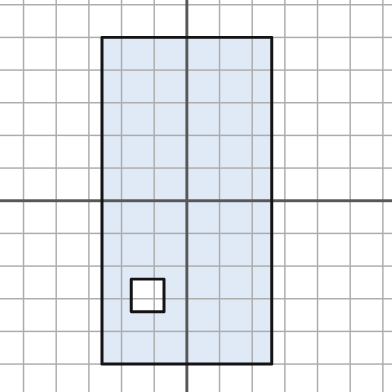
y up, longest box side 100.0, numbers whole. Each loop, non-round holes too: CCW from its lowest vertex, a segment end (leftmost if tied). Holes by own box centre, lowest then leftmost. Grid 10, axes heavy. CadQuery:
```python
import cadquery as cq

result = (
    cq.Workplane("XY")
    .moveTo(-26.0, -50.0)
    .lineTo(26.0, -50.0)
    .lineTo(26.0, 50.0)
    .lineTo(-26.0, 50.0)
    .close()
    .moveTo(-17.0, -34.0)
    .lineTo(-7.0, -34.0)
    .lineTo(-7.0, -24.0)
    .lineTo(-17.0, -24.0)
    .close()
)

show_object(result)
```